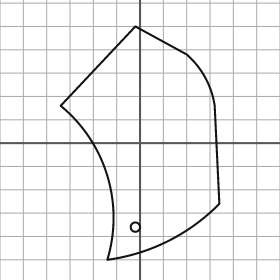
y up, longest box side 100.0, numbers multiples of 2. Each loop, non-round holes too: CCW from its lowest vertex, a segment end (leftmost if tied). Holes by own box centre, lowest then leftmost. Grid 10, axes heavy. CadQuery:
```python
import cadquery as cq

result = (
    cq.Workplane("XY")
    .moveTo(-14.0, -50.0)
    .threePointArc((12.0, -42.0), (34.0, -26.0))
    .lineTo(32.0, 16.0)
    .threePointArc((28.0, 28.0), (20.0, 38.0))
    .lineTo(-2.0, 50.0)
    .lineTo(-34.0, 16.0)
    .threePointArc((-14.0, -14.0), (-14.0, -50.0))
    .close()
    .moveTo(-2.0, -36.0)
    .circle(2.0)
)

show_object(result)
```